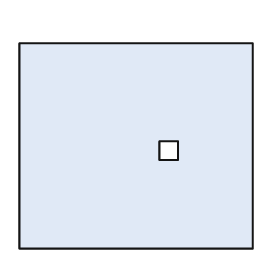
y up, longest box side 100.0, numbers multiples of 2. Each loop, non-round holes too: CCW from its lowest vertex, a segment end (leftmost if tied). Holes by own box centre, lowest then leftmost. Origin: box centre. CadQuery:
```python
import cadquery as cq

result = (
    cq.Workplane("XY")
    .moveTo(-50.0, -44.0)
    .lineTo(50.0, -44.0)
    .lineTo(50.0, 44.0)
    .lineTo(-50.0, 44.0)
    .close()
    .moveTo(10.0, -6.0)
    .lineTo(18.0, -6.0)
    .lineTo(18.0, 2.0)
    .lineTo(10.0, 2.0)
    .close()
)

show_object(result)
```